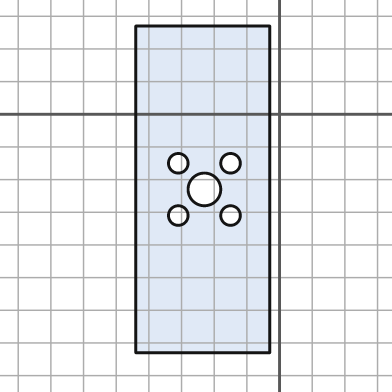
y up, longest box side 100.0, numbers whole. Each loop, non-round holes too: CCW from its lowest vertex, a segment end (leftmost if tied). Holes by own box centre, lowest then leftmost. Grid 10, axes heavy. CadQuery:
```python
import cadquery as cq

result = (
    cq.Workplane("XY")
    .moveTo(-44.0, -73.0)
    .lineTo(-3.0, -73.0)
    .lineTo(-3.0, 27.0)
    .lineTo(-44.0, 27.0)
    .close()
    .moveTo(-31.0, -31.0)
    .circle(3.0)
    .moveTo(-15.0, -31.0)
    .circle(3.0)
    .moveTo(-23.0, -23.0)
    .circle(5.0)
    .moveTo(-31.0, -15.0)
    .circle(3.0)
    .moveTo(-15.0, -15.0)
    .circle(3.0)
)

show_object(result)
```